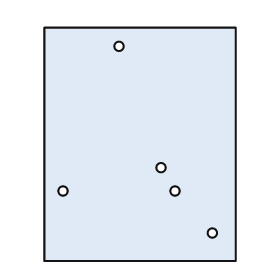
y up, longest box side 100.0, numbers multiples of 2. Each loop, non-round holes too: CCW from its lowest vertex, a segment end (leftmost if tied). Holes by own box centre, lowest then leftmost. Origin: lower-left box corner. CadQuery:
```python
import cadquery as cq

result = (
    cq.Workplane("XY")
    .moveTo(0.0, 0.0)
    .lineTo(82.0, 0.0)
    .lineTo(82.0, 100.0)
    .lineTo(0.0, 100.0)
    .close()
    .moveTo(72.0, 12.0)
    .circle(2.0)
    .moveTo(8.0, 30.0)
    .circle(2.0)
    .moveTo(56.0, 30.0)
    .circle(2.0)
    .moveTo(50.0, 40.0)
    .circle(2.0)
    .moveTo(32.0, 92.0)
    .circle(2.0)
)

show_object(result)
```